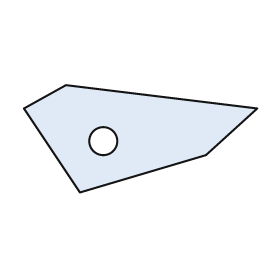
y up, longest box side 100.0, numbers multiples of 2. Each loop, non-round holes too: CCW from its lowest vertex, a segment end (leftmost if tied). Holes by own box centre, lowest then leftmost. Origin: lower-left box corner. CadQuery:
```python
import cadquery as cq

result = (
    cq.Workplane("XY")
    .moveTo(24.0, 0.0)
    .lineTo(78.0, 16.0)
    .lineTo(100.0, 36.0)
    .lineTo(18.0, 46.0)
    .lineTo(0.0, 36.0)
    .close()
    .moveTo(34.0, 22.0)
    .circle(6.0)
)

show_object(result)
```